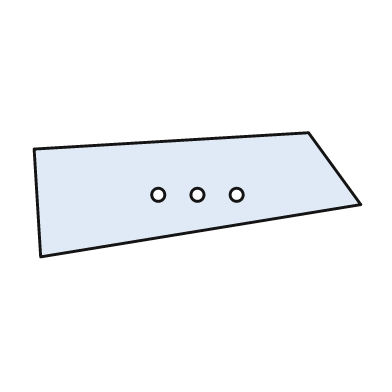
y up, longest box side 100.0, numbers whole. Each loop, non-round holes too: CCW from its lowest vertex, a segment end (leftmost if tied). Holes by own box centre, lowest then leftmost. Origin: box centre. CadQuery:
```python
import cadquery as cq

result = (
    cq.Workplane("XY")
    .moveTo(-48.0, -19.0)
    .lineTo(50.0, -3.0)
    .lineTo(34.0, 19.0)
    .lineTo(-50.0, 14.0)
    .close()
    .moveTo(-12.0, 0.0)
    .circle(2.0)
    .moveTo(0.0, 0.0)
    .circle(2.0)
    .moveTo(12.0, 0.0)
    .circle(2.0)
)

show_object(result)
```